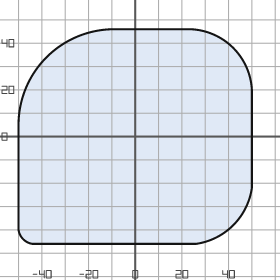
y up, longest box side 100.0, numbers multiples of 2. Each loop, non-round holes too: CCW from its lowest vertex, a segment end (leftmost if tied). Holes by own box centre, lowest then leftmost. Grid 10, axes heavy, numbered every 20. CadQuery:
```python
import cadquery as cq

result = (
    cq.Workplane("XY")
    .moveTo(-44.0, -46.0)
    .lineTo(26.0, -46.0)
    .threePointArc((42.0, -38.0), (50.0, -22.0))
    .lineTo(50.0, 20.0)
    .threePointArc((42.0, 38.0), (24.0, 46.0))
    .lineTo(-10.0, 46.0)
    .threePointArc((-38.0, 34.0), (-50.0, 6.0))
    .lineTo(-50.0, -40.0)
    .threePointArc((-48.0, -44.0), (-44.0, -46.0))
    .close()
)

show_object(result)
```